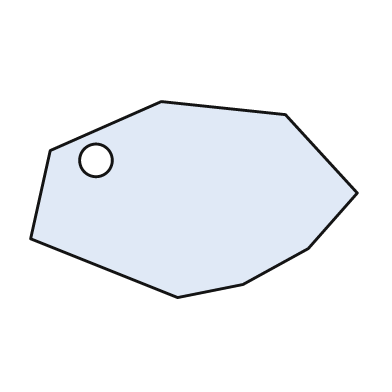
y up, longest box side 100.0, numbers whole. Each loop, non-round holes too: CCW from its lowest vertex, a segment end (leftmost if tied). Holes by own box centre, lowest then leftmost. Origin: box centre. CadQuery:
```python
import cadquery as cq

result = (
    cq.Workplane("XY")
    .moveTo(-5.0, -30.0)
    .lineTo(15.0, -26.0)
    .lineTo(35.0, -15.0)
    .lineTo(50.0, 2.0)
    .lineTo(28.0, 26.0)
    .lineTo(-10.0, 30.0)
    .lineTo(-44.0, 15.0)
    .lineTo(-50.0, -12.0)
    .close()
    .moveTo(-30.0, 12.0)
    .circle(5.0)
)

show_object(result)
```